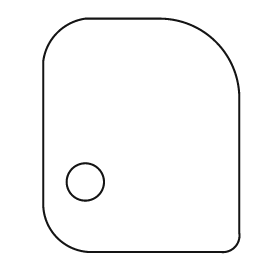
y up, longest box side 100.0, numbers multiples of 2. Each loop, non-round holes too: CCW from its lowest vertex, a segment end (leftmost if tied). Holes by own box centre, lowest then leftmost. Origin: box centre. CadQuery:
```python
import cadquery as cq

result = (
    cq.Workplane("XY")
    .moveTo(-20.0, -50.0)
    .lineTo(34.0, -50.0)
    .threePointArc((40.0, -48.0), (42.0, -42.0))
    .lineTo(42.0, 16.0)
    .threePointArc((32.0, 40.0), (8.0, 50.0))
    .lineTo(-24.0, 50.0)
    .threePointArc((-36.0, 44.0), (-42.0, 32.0))
    .lineTo(-42.0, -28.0)
    .threePointArc((-36.0, -44.0), (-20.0, -50.0))
    .close()
    .moveTo(-24.0, -20.0)
    .circle(8.0)
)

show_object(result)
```